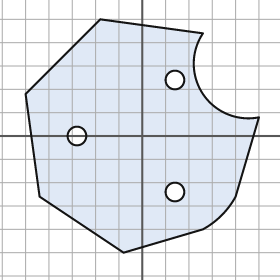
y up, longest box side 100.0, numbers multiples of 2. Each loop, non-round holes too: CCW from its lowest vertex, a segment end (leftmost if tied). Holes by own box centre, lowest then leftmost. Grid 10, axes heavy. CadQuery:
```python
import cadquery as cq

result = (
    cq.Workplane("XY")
    .moveTo(-8.0, -50.0)
    .lineTo(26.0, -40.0)
    .threePointArc((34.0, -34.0), (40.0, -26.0))
    .lineTo(50.0, 8.0)
    .threePointArc((26.0, 18.0), (26.0, 44.0))
    .lineTo(-18.0, 50.0)
    .lineTo(-50.0, 18.0)
    .lineTo(-44.0, -26.0)
    .close()
    .moveTo(14.0, -24.0)
    .circle(4.0)
    .moveTo(-28.0, 0.0)
    .circle(4.0)
    .moveTo(14.0, 24.0)
    .circle(4.0)
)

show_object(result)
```